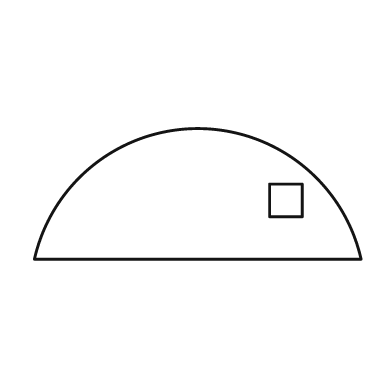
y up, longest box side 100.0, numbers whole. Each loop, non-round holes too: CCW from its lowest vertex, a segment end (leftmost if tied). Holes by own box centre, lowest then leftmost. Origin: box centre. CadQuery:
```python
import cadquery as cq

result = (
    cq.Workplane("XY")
    .moveTo(-50.0, -20.0)
    .lineTo(50.0, -20.0)
    .threePointArc((0.0, 20.0), (-50.0, -20.0))
    .close()
    .moveTo(22.0, -7.0)
    .lineTo(32.0, -7.0)
    .lineTo(32.0, 3.0)
    .lineTo(22.0, 3.0)
    .close()
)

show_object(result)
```